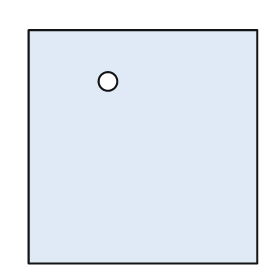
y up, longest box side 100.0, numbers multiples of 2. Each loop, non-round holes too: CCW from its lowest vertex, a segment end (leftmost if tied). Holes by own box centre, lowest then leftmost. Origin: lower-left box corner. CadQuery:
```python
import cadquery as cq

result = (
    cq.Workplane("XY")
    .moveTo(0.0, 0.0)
    .lineTo(98.0, 0.0)
    .lineTo(98.0, 100.0)
    .lineTo(0.0, 100.0)
    .close()
    .moveTo(34.0, 78.0)
    .circle(4.0)
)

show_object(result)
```